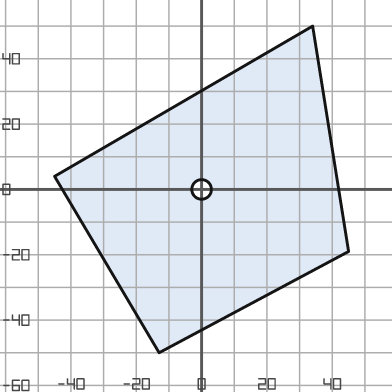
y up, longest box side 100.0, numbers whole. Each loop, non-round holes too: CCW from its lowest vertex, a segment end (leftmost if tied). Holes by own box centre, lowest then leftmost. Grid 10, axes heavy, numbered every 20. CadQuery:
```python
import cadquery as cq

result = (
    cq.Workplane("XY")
    .moveTo(-13.0, -50.0)
    .lineTo(45.0, -19.0)
    .lineTo(34.0, 50.0)
    .lineTo(-45.0, 4.0)
    .close()
    .moveTo(0.0, 0.0)
    .circle(3.0)
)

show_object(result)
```